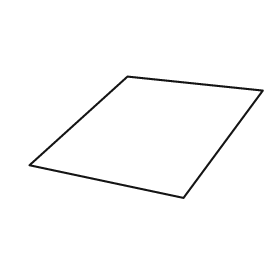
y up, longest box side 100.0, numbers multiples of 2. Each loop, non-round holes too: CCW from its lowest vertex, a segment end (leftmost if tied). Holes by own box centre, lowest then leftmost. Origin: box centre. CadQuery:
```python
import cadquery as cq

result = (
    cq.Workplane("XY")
    .moveTo(16.0, -26.0)
    .lineTo(50.0, 20.0)
    .lineTo(-8.0, 26.0)
    .lineTo(-50.0, -12.0)
    .close()
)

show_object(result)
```